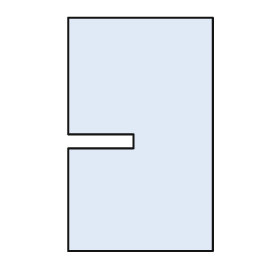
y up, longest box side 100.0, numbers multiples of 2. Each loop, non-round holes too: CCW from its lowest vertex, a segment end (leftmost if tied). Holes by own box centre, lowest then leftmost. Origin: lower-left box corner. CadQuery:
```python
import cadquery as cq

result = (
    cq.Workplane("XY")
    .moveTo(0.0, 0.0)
    .lineTo(62.0, 0.0)
    .lineTo(62.0, 100.0)
    .lineTo(0.0, 100.0)
    .lineTo(0.0, 50.0)
    .lineTo(28.0, 50.0)
    .lineTo(28.0, 44.0)
    .lineTo(0.0, 44.0)
    .close()
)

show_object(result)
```